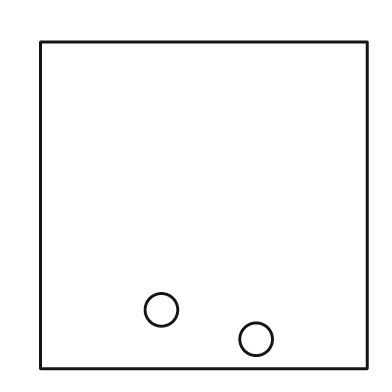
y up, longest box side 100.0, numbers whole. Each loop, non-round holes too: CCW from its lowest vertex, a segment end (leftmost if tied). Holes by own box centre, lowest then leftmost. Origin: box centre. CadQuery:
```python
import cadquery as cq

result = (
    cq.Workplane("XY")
    .moveTo(-50.0, -50.0)
    .lineTo(50.0, -50.0)
    .lineTo(50.0, 50.0)
    .lineTo(-50.0, 50.0)
    .close()
    .moveTo(16.0, -41.0)
    .circle(5.0)
    .moveTo(-13.0, -32.0)
    .circle(5.0)
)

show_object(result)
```